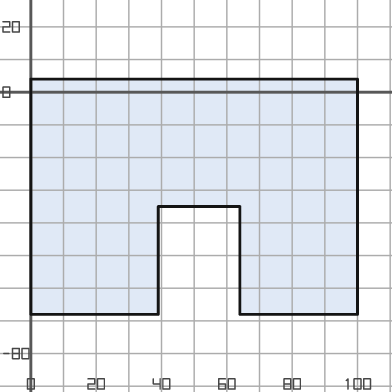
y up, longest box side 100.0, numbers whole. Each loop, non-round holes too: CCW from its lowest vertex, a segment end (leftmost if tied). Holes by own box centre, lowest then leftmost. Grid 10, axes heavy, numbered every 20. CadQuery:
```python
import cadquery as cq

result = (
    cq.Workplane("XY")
    .moveTo(0.0, -68.0)
    .lineTo(39.0, -68.0)
    .lineTo(39.0, -35.0)
    .lineTo(64.0, -35.0)
    .lineTo(64.0, -68.0)
    .lineTo(100.0, -68.0)
    .lineTo(100.0, 4.0)
    .lineTo(0.0, 4.0)
    .close()
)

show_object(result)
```